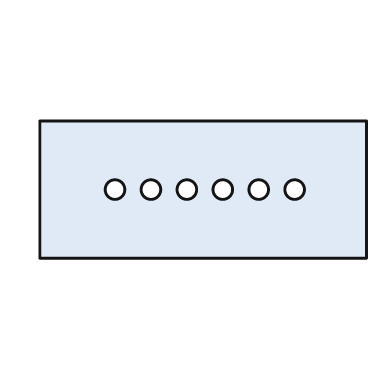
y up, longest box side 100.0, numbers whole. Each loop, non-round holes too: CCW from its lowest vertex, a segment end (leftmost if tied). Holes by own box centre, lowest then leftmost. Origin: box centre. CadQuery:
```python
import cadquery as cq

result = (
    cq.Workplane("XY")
    .moveTo(-50.0, -21.0)
    .lineTo(50.0, -21.0)
    .lineTo(50.0, 21.0)
    .lineTo(-50.0, 21.0)
    .close()
    .moveTo(-27.0, 0.0)
    .circle(3.0)
    .moveTo(-16.0, 0.0)
    .circle(3.0)
    .moveTo(-5.0, 0.0)
    .circle(3.0)
    .moveTo(6.0, 0.0)
    .circle(3.0)
    .moveTo(17.0, 0.0)
    .circle(3.0)
    .moveTo(28.0, 0.0)
    .circle(3.0)
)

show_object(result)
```